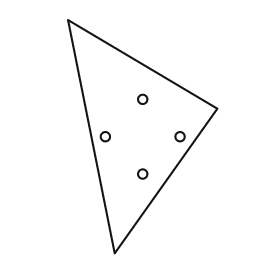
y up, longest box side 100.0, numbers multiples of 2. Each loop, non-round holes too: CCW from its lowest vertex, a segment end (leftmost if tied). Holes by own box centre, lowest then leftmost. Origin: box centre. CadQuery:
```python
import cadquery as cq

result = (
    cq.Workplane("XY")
    .moveTo(-12.0, -50.0)
    .lineTo(32.0, 12.0)
    .lineTo(-32.0, 50.0)
    .close()
    .moveTo(0.0, -16.0)
    .circle(2.0)
    .moveTo(-16.0, 0.0)
    .circle(2.0)
    .moveTo(16.0, 0.0)
    .circle(2.0)
    .moveTo(0.0, 16.0)
    .circle(2.0)
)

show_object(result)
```